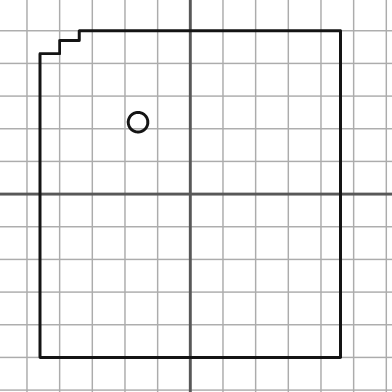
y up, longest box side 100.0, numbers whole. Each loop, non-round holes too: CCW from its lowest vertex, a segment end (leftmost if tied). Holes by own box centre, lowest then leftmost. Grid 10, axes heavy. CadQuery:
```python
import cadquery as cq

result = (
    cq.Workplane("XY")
    .moveTo(-46.0, -50.0)
    .lineTo(46.0, -50.0)
    .lineTo(46.0, 50.0)
    .lineTo(-34.0, 50.0)
    .lineTo(-34.0, 47.0)
    .lineTo(-40.0, 47.0)
    .lineTo(-40.0, 43.0)
    .lineTo(-46.0, 43.0)
    .close()
    .moveTo(-16.0, 22.0)
    .circle(3.0)
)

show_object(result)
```